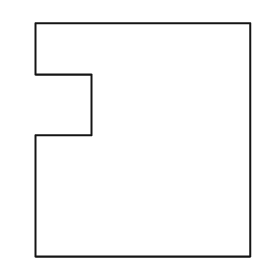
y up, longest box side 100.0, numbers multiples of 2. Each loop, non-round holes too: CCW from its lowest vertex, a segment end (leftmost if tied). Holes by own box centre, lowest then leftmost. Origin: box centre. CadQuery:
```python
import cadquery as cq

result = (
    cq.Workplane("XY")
    .moveTo(-46.0, -50.0)
    .lineTo(46.0, -50.0)
    .lineTo(46.0, 50.0)
    .lineTo(-46.0, 50.0)
    .lineTo(-46.0, 28.0)
    .lineTo(-22.0, 28.0)
    .lineTo(-22.0, 2.0)
    .lineTo(-46.0, 2.0)
    .close()
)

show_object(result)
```